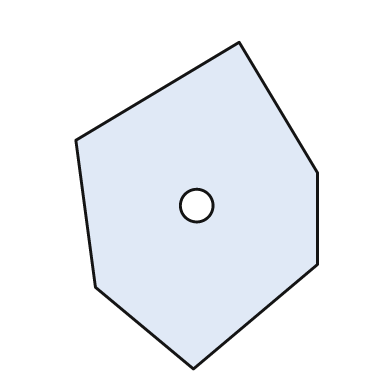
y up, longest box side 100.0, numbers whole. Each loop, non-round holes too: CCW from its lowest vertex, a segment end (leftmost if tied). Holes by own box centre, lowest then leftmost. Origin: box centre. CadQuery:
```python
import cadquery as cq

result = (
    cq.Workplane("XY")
    .moveTo(-1.0, -50.0)
    .lineTo(37.0, -18.0)
    .lineTo(37.0, 10.0)
    .lineTo(13.0, 50.0)
    .lineTo(-37.0, 20.0)
    .lineTo(-31.0, -25.0)
    .close()
    .moveTo(0.0, 0.0)
    .circle(5.0)
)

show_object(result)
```